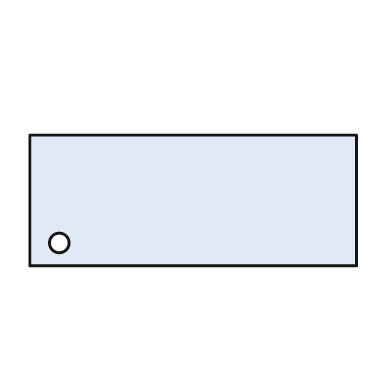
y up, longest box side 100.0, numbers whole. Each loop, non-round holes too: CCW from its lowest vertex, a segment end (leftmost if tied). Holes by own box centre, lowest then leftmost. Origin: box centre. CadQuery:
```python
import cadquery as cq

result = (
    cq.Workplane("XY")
    .moveTo(-50.0, -20.0)
    .lineTo(50.0, -20.0)
    .lineTo(50.0, 20.0)
    .lineTo(-50.0, 20.0)
    .close()
    .moveTo(-41.0, -13.0)
    .circle(3.0)
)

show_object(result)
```